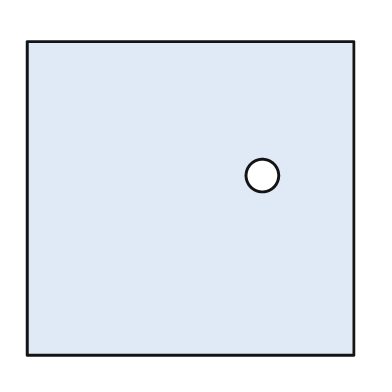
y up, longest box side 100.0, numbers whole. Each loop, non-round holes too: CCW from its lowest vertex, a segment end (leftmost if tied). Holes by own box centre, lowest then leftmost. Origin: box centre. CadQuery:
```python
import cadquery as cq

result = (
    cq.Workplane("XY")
    .moveTo(-50.0, -48.0)
    .lineTo(50.0, -48.0)
    .lineTo(50.0, 48.0)
    .lineTo(-50.0, 48.0)
    .close()
    .moveTo(22.0, 7.0)
    .circle(5.0)
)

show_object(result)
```